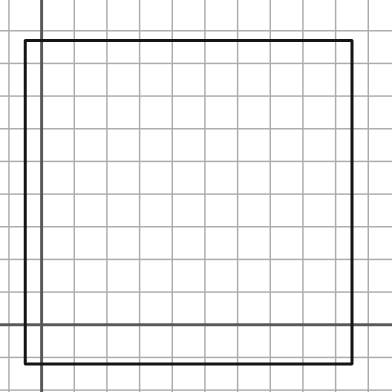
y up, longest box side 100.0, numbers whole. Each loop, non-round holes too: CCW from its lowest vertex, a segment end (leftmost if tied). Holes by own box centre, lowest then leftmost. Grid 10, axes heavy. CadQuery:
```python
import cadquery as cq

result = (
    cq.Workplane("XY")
    .moveTo(-5.0, -12.0)
    .lineTo(95.0, -12.0)
    .lineTo(95.0, 87.0)
    .lineTo(-5.0, 87.0)
    .close()
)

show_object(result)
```